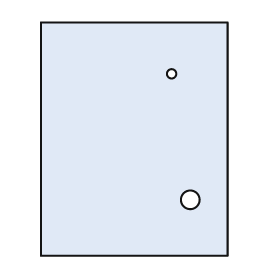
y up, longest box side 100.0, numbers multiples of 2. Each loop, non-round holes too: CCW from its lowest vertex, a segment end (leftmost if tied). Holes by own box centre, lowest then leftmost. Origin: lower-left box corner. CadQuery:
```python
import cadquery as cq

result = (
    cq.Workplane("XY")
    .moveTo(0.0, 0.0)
    .lineTo(80.0, 0.0)
    .lineTo(80.0, 100.0)
    .lineTo(0.0, 100.0)
    .close()
    .moveTo(64.0, 24.0)
    .circle(4.0)
    .moveTo(56.0, 78.0)
    .circle(2.0)
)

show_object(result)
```